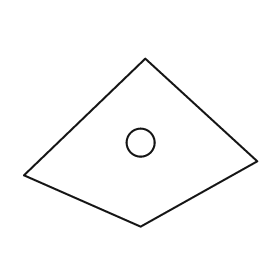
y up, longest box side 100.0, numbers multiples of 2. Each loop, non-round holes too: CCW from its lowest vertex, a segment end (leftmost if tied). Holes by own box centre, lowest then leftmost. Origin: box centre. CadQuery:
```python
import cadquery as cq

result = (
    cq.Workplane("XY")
    .moveTo(0.0, -36.0)
    .lineTo(50.0, -8.0)
    .lineTo(2.0, 36.0)
    .lineTo(-50.0, -14.0)
    .close()
    .moveTo(0.0, 0.0)
    .circle(6.0)
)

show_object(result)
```